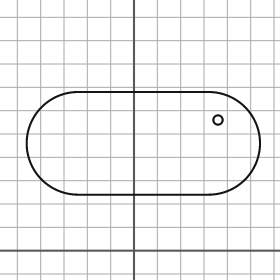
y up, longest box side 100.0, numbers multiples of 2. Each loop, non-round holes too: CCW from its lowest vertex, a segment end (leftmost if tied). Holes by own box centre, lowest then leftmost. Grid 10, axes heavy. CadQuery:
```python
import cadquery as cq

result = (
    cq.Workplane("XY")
    .moveTo(-24.0, 24.0)
    .lineTo(32.0, 24.0)
    .threePointArc((54.0, 46.0), (32.0, 68.0))
    .lineTo(-24.0, 68.0)
    .threePointArc((-46.0, 46.0), (-24.0, 24.0))
    .close()
    .moveTo(36.0, 56.0)
    .circle(2.0)
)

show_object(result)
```